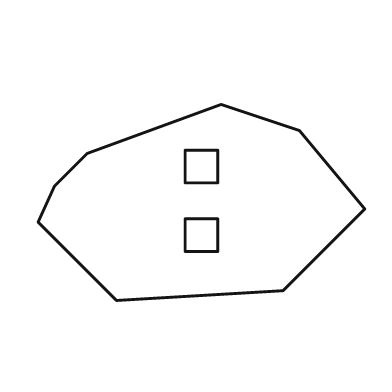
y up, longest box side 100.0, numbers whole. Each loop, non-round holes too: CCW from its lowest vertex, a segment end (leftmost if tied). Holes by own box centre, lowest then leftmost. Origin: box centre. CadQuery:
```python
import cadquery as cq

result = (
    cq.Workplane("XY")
    .moveTo(-26.0, -30.0)
    .lineTo(25.0, -27.0)
    .lineTo(50.0, -2.0)
    .lineTo(30.0, 22.0)
    .lineTo(6.0, 30.0)
    .lineTo(-35.0, 15.0)
    .lineTo(-45.0, 5.0)
    .lineTo(-50.0, -6.0)
    .close()
    .moveTo(-5.0, -15.0)
    .lineTo(5.0, -15.0)
    .lineTo(5.0, -5.0)
    .lineTo(-5.0, -5.0)
    .close()
    .moveTo(-5.0, 6.0)
    .lineTo(5.0, 6.0)
    .lineTo(5.0, 16.0)
    .lineTo(-5.0, 16.0)
    .close()
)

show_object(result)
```